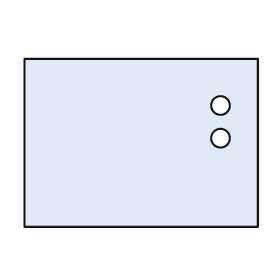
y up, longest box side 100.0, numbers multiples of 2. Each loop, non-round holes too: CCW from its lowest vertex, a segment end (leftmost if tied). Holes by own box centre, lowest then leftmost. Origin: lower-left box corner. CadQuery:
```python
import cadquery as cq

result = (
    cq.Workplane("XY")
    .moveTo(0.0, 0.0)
    .lineTo(100.0, 0.0)
    .lineTo(100.0, 72.0)
    .lineTo(0.0, 72.0)
    .close()
    .moveTo(84.0, 38.0)
    .circle(4.0)
    .moveTo(84.0, 52.0)
    .circle(4.0)
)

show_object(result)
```